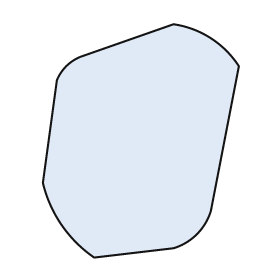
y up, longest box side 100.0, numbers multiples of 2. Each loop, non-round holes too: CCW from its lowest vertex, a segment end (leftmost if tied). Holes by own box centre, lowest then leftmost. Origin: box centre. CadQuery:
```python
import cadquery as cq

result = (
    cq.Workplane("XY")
    .moveTo(-20.0, -50.0)
    .lineTo(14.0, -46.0)
    .threePointArc((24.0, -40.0), (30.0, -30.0))
    .lineTo(42.0, 32.0)
    .threePointArc((30.0, 44.0), (14.0, 50.0))
    .lineTo(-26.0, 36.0)
    .threePointArc((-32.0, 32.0), (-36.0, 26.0))
    .lineTo(-42.0, -18.0)
    .threePointArc((-34.0, -36.0), (-20.0, -50.0))
    .close()
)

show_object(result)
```